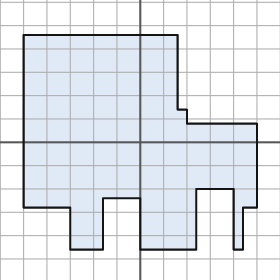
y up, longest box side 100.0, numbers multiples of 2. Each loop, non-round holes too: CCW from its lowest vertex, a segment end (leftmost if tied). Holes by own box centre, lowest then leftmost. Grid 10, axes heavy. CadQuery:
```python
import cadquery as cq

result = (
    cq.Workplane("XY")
    .moveTo(-30.0, -46.0)
    .lineTo(-16.0, -46.0)
    .lineTo(-16.0, -24.0)
    .lineTo(0.0, -24.0)
    .lineTo(0.0, -46.0)
    .lineTo(24.0, -46.0)
    .lineTo(24.0, -20.0)
    .lineTo(40.0, -20.0)
    .lineTo(40.0, -46.0)
    .lineTo(44.0, -46.0)
    .lineTo(44.0, -28.0)
    .lineTo(50.0, -28.0)
    .lineTo(50.0, 8.0)
    .lineTo(20.0, 8.0)
    .lineTo(20.0, 14.0)
    .lineTo(16.0, 14.0)
    .lineTo(16.0, 46.0)
    .lineTo(-50.0, 46.0)
    .lineTo(-50.0, -28.0)
    .lineTo(-30.0, -28.0)
    .close()
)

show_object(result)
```